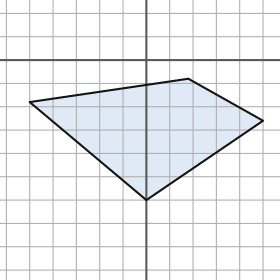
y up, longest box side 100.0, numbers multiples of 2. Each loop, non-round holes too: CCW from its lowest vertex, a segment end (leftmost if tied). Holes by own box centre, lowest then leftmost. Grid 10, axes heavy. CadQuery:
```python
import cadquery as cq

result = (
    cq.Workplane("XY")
    .moveTo(0.0, -60.0)
    .lineTo(50.0, -26.0)
    .lineTo(18.0, -8.0)
    .lineTo(-50.0, -18.0)
    .close()
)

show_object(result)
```